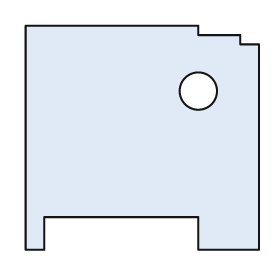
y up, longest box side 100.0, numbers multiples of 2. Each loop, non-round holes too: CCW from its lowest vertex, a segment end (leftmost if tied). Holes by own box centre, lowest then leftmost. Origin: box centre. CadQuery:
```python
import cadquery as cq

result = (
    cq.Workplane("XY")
    .moveTo(-50.0, -48.0)
    .lineTo(-42.0, -48.0)
    .lineTo(-42.0, -34.0)
    .lineTo(24.0, -34.0)
    .lineTo(24.0, -48.0)
    .lineTo(50.0, -48.0)
    .lineTo(50.0, 40.0)
    .lineTo(42.0, 40.0)
    .lineTo(42.0, 44.0)
    .lineTo(24.0, 44.0)
    .lineTo(24.0, 48.0)
    .lineTo(-50.0, 48.0)
    .close()
    .moveTo(24.0, 20.0)
    .circle(8.0)
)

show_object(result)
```